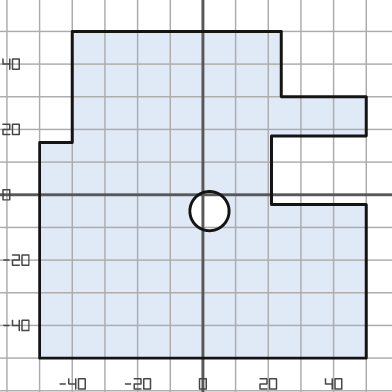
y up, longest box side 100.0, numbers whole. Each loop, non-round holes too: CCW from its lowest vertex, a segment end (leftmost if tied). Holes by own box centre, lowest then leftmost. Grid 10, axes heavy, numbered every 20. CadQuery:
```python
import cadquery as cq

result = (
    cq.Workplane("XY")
    .moveTo(-50.0, -50.0)
    .lineTo(50.0, -50.0)
    .lineTo(50.0, -3.0)
    .lineTo(21.0, -3.0)
    .lineTo(21.0, 18.0)
    .lineTo(50.0, 18.0)
    .lineTo(50.0, 30.0)
    .lineTo(24.0, 30.0)
    .lineTo(24.0, 50.0)
    .lineTo(-40.0, 50.0)
    .lineTo(-40.0, 16.0)
    .lineTo(-50.0, 16.0)
    .close()
    .moveTo(2.0, -5.0)
    .circle(6.0)
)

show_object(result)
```